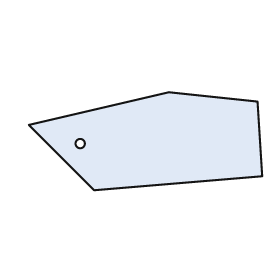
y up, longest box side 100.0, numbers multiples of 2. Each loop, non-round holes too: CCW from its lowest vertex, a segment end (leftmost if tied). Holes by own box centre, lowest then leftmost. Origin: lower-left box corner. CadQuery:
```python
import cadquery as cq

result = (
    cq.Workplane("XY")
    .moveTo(28.0, 0.0)
    .lineTo(100.0, 6.0)
    .lineTo(98.0, 38.0)
    .lineTo(60.0, 42.0)
    .lineTo(0.0, 28.0)
    .close()
    .moveTo(22.0, 20.0)
    .circle(2.0)
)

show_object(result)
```